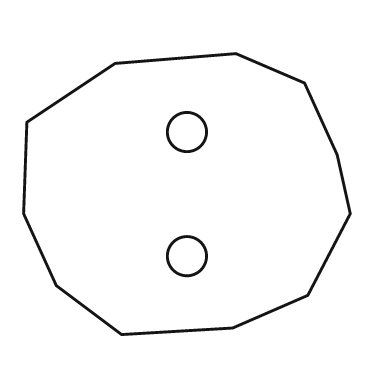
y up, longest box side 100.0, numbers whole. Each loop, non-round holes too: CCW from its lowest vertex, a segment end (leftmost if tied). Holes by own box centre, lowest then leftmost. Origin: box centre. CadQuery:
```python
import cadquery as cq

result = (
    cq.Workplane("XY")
    .moveTo(-20.0, -43.0)
    .lineTo(14.0, -41.0)
    .lineTo(37.0, -31.0)
    .lineTo(50.0, -6.0)
    .lineTo(46.0, 12.0)
    .lineTo(36.0, 34.0)
    .lineTo(15.0, 43.0)
    .lineTo(-22.0, 40.0)
    .lineTo(-49.0, 22.0)
    .lineTo(-50.0, -6.0)
    .lineTo(-40.0, -28.0)
    .close()
    .moveTo(0.0, -19.0)
    .circle(6.0)
    .moveTo(0.0, 19.0)
    .circle(6.0)
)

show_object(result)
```